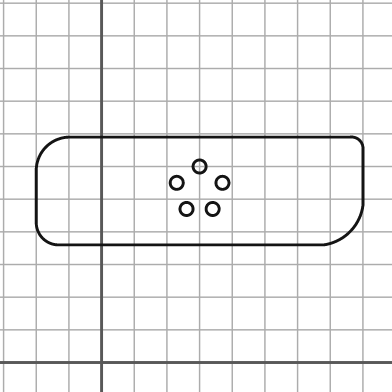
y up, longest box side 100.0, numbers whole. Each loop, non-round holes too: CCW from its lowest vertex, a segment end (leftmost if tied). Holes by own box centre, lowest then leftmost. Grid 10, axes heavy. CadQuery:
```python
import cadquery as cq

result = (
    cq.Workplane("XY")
    .moveTo(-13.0, 36.0)
    .lineTo(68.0, 36.0)
    .threePointArc((76.0, 40.0), (80.0, 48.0))
    .lineTo(80.0, 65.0)
    .threePointArc((79.0, 68.0), (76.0, 69.0))
    .lineTo(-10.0, 69.0)
    .threePointArc((-17.0, 66.0), (-20.0, 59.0))
    .lineTo(-20.0, 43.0)
    .threePointArc((-18.0, 38.0), (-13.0, 36.0))
    .close()
    .moveTo(26.0, 47.0)
    .circle(2.0)
    .moveTo(34.0, 47.0)
    .circle(2.0)
    .moveTo(23.0, 55.0)
    .circle(2.0)
    .moveTo(37.0, 55.0)
    .circle(2.0)
    .moveTo(30.0, 60.0)
    .circle(2.0)
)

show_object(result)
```